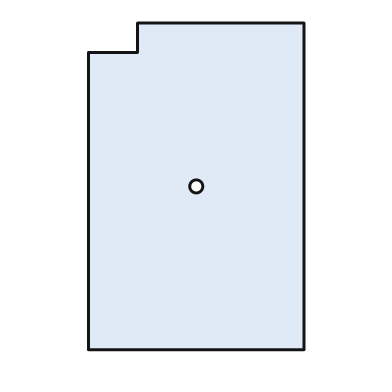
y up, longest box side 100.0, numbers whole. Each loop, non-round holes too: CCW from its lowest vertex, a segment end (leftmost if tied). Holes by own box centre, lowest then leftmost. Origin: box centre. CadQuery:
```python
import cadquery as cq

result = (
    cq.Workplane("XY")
    .moveTo(-33.0, -50.0)
    .lineTo(33.0, -50.0)
    .lineTo(33.0, 50.0)
    .lineTo(-18.0, 50.0)
    .lineTo(-18.0, 41.0)
    .lineTo(-33.0, 41.0)
    .close()
    .moveTo(0.0, 0.0)
    .circle(2.0)
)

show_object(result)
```